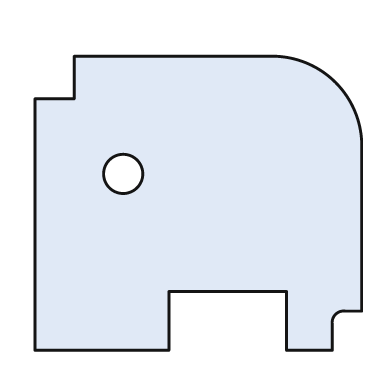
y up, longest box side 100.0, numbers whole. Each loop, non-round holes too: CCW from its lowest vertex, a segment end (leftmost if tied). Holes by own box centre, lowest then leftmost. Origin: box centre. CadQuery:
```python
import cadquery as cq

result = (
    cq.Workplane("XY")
    .moveTo(-50.0, -45.0)
    .lineTo(-9.0, -45.0)
    .lineTo(-9.0, -27.0)
    .lineTo(27.0, -27.0)
    .lineTo(27.0, -45.0)
    .lineTo(41.0, -45.0)
    .lineTo(41.0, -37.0)
    .threePointArc((42.0, -34.0), (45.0, -33.0))
    .lineTo(50.0, -33.0)
    .lineTo(50.0, 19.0)
    .threePointArc((42.0, 37.0), (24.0, 45.0))
    .lineTo(-38.0, 45.0)
    .lineTo(-38.0, 32.0)
    .lineTo(-50.0, 32.0)
    .close()
    .moveTo(-23.0, 9.0)
    .circle(6.0)
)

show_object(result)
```